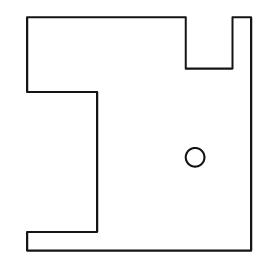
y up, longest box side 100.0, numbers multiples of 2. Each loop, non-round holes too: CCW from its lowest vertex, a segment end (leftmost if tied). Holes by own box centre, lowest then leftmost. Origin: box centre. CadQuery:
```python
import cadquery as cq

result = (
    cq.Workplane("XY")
    .moveTo(-48.0, -50.0)
    .lineTo(48.0, -50.0)
    .lineTo(48.0, 50.0)
    .lineTo(40.0, 50.0)
    .lineTo(40.0, 28.0)
    .lineTo(20.0, 28.0)
    .lineTo(20.0, 50.0)
    .lineTo(-48.0, 50.0)
    .lineTo(-48.0, 18.0)
    .lineTo(-18.0, 18.0)
    .lineTo(-18.0, -42.0)
    .lineTo(-48.0, -42.0)
    .close()
    .moveTo(24.0, -10.0)
    .circle(4.0)
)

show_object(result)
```